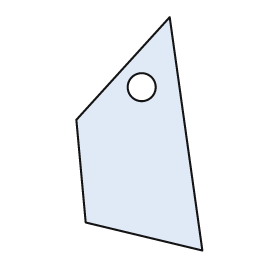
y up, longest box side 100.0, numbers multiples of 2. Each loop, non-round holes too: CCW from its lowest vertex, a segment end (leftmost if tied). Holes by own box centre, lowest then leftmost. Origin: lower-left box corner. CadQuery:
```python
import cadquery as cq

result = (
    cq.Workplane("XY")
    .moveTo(54.0, 0.0)
    .lineTo(40.0, 100.0)
    .lineTo(0.0, 56.0)
    .lineTo(4.0, 12.0)
    .close()
    .moveTo(28.0, 70.0)
    .circle(6.0)
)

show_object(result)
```